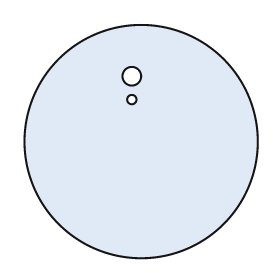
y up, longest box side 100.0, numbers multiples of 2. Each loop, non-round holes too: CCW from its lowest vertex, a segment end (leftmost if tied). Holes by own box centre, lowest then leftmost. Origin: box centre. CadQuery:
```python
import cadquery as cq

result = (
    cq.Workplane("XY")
    .moveTo(0.0, 0.0)
    .circle(50.0)
    .moveTo(-4.0, 18.0)
    .circle(2.0)
    .moveTo(-4.0, 28.0)
    .circle(4.0)
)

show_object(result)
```